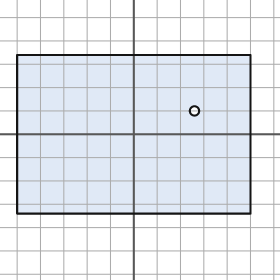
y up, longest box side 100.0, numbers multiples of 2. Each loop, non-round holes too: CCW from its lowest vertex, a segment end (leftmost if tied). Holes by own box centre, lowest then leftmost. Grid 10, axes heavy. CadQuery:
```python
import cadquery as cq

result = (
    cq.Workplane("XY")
    .moveTo(-50.0, -34.0)
    .lineTo(50.0, -34.0)
    .lineTo(50.0, 34.0)
    .lineTo(-50.0, 34.0)
    .close()
    .moveTo(26.0, 10.0)
    .circle(2.0)
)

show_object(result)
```